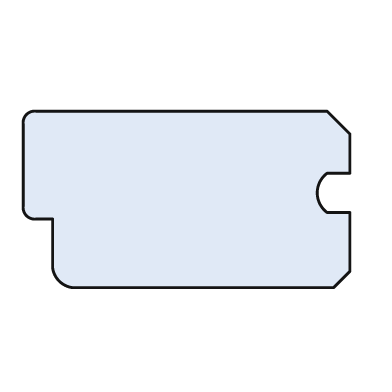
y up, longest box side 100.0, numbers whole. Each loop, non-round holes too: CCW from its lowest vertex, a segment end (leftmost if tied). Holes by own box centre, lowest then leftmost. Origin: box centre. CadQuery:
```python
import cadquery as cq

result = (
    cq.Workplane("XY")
    .moveTo(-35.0, -27.0)
    .lineTo(45.0, -27.0)
    .lineTo(50.0, -22.0)
    .lineTo(50.0, -4.0)
    .lineTo(43.0, -4.0)
    .threePointArc((40.0, 2.0), (43.0, 8.0))
    .lineTo(50.0, 8.0)
    .lineTo(50.0, 20.0)
    .lineTo(43.0, 27.0)
    .lineTo(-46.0, 27.0)
    .threePointArc((-49.0, 26.0), (-50.0, 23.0))
    .lineTo(-50.0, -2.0)
    .threePointArc((-49.0, -5.0), (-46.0, -6.0))
    .lineTo(-41.0, -6.0)
    .lineTo(-41.0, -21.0)
    .threePointArc((-39.0, -25.0), (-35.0, -27.0))
    .close()
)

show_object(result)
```